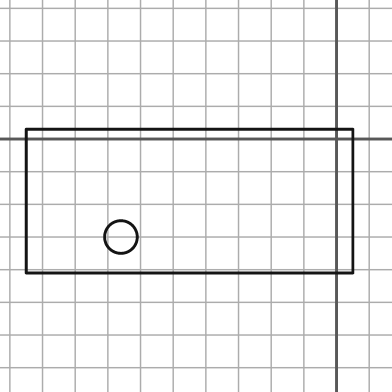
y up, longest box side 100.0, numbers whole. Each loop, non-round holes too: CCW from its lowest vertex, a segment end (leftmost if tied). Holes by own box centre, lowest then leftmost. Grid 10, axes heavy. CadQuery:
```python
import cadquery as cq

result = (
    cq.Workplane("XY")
    .moveTo(-95.0, -41.0)
    .lineTo(5.0, -41.0)
    .lineTo(5.0, 3.0)
    .lineTo(-95.0, 3.0)
    .close()
    .moveTo(-66.0, -30.0)
    .circle(5.0)
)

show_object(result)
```